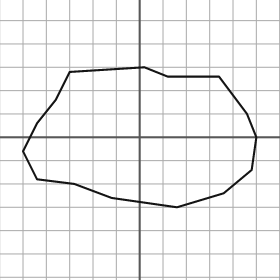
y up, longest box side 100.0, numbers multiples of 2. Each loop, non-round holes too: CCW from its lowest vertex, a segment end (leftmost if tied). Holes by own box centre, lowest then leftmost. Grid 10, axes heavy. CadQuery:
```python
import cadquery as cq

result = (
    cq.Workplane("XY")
    .moveTo(16.0, -30.0)
    .lineTo(36.0, -24.0)
    .lineTo(48.0, -14.0)
    .lineTo(50.0, 0.0)
    .lineTo(46.0, 10.0)
    .lineTo(34.0, 26.0)
    .lineTo(12.0, 26.0)
    .lineTo(2.0, 30.0)
    .lineTo(-30.0, 28.0)
    .lineTo(-36.0, 16.0)
    .lineTo(-44.0, 6.0)
    .lineTo(-50.0, -6.0)
    .lineTo(-44.0, -18.0)
    .lineTo(-28.0, -20.0)
    .lineTo(-12.0, -26.0)
    .close()
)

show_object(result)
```